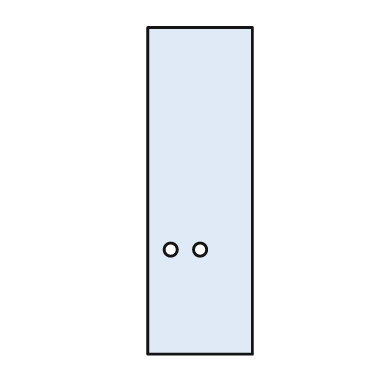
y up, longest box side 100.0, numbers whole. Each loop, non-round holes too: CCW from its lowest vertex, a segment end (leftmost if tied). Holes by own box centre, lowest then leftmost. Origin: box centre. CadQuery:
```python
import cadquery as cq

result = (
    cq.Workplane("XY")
    .moveTo(-16.0, -50.0)
    .lineTo(16.0, -50.0)
    .lineTo(16.0, 50.0)
    .lineTo(-16.0, 50.0)
    .close()
    .moveTo(-9.0, -18.0)
    .circle(2.0)
    .moveTo(0.0, -18.0)
    .circle(2.0)
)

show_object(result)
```